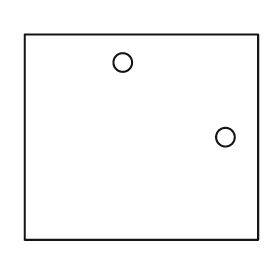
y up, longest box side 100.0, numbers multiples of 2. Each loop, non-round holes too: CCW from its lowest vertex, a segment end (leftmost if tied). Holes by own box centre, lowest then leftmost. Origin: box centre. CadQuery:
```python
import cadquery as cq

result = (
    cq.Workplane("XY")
    .moveTo(-50.0, -44.0)
    .lineTo(50.0, -44.0)
    .lineTo(50.0, 44.0)
    .lineTo(-50.0, 44.0)
    .close()
    .moveTo(36.0, 0.0)
    .circle(4.0)
    .moveTo(-8.0, 32.0)
    .circle(4.0)
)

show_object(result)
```